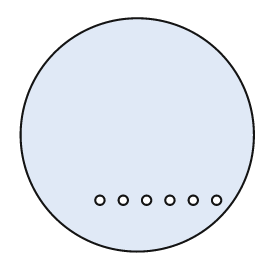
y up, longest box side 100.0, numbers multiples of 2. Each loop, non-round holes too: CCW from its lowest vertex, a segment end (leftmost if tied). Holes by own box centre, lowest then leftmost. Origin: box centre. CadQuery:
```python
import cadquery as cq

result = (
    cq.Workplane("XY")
    .moveTo(0.0, 0.0)
    .circle(50.0)
    .moveTo(-16.0, -28.0)
    .circle(2.0)
    .moveTo(-6.0, -28.0)
    .circle(2.0)
    .moveTo(4.0, -28.0)
    .circle(2.0)
    .moveTo(14.0, -28.0)
    .circle(2.0)
    .moveTo(24.0, -28.0)
    .circle(2.0)
    .moveTo(34.0, -28.0)
    .circle(2.0)
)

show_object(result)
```